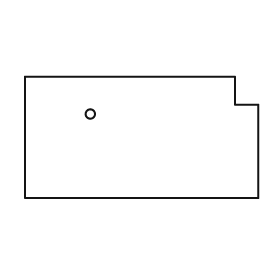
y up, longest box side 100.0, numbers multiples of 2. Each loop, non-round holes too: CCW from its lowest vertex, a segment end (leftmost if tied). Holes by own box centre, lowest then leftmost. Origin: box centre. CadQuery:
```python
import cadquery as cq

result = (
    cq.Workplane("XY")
    .moveTo(-50.0, -26.0)
    .lineTo(50.0, -26.0)
    .lineTo(50.0, 14.0)
    .lineTo(40.0, 14.0)
    .lineTo(40.0, 26.0)
    .lineTo(-50.0, 26.0)
    .close()
    .moveTo(-22.0, 10.0)
    .circle(2.0)
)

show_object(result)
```